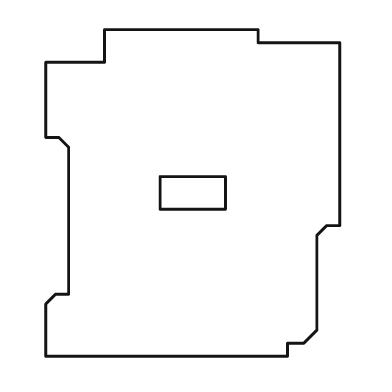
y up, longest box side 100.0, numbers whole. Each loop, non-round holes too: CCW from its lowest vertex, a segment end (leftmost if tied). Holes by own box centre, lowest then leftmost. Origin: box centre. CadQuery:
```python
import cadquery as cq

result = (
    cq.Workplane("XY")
    .moveTo(-45.0, -50.0)
    .lineTo(29.0, -50.0)
    .lineTo(29.0, -46.0)
    .lineTo(34.0, -46.0)
    .lineTo(38.0, -42.0)
    .lineTo(38.0, -13.0)
    .lineTo(41.0, -10.0)
    .lineTo(45.0, -10.0)
    .lineTo(45.0, 46.0)
    .lineTo(20.0, 46.0)
    .lineTo(20.0, 50.0)
    .lineTo(-27.0, 50.0)
    .lineTo(-27.0, 40.0)
    .lineTo(-45.0, 40.0)
    .lineTo(-45.0, 17.0)
    .lineTo(-41.0, 17.0)
    .lineTo(-38.0, 14.0)
    .lineTo(-38.0, -31.0)
    .lineTo(-42.0, -31.0)
    .lineTo(-45.0, -34.0)
    .close()
    .moveTo(-10.0, -5.0)
    .lineTo(10.0, -5.0)
    .lineTo(10.0, 5.0)
    .lineTo(-10.0, 5.0)
    .close()
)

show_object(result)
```